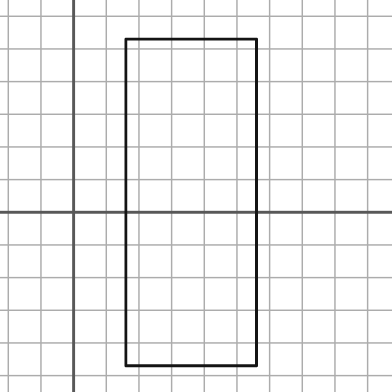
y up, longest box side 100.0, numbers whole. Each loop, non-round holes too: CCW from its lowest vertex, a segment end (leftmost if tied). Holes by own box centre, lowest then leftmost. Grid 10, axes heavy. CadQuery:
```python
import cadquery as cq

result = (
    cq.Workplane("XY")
    .moveTo(16.0, -47.0)
    .lineTo(56.0, -47.0)
    .lineTo(56.0, 53.0)
    .lineTo(16.0, 53.0)
    .close()
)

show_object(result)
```